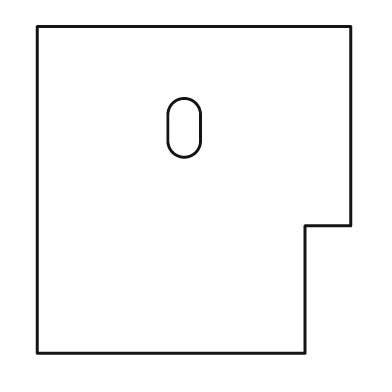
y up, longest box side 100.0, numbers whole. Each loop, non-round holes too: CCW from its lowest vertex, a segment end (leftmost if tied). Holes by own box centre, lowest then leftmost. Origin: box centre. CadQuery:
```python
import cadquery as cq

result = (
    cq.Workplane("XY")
    .moveTo(-48.0, -50.0)
    .lineTo(34.0, -50.0)
    .lineTo(34.0, -11.0)
    .lineTo(48.0, -11.0)
    .lineTo(48.0, 50.0)
    .lineTo(-48.0, 50.0)
    .close()
    .moveTo(-8.0, 15.0)
    .threePointArc((-3.0, 10.0), (2.0, 15.0))
    .lineTo(2.0, 23.0)
    .threePointArc((-3.0, 28.0), (-8.0, 23.0))
    .close()
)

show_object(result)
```